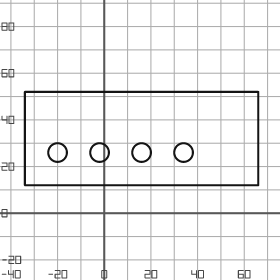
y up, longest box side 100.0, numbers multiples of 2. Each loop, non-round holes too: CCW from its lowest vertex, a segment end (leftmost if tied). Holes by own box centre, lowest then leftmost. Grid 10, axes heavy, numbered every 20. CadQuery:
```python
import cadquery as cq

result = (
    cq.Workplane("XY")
    .moveTo(-34.0, 12.0)
    .lineTo(66.0, 12.0)
    .lineTo(66.0, 52.0)
    .lineTo(-34.0, 52.0)
    .close()
    .moveTo(-20.0, 26.0)
    .circle(4.0)
    .moveTo(-2.0, 26.0)
    .circle(4.0)
    .moveTo(16.0, 26.0)
    .circle(4.0)
    .moveTo(34.0, 26.0)
    .circle(4.0)
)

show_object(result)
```